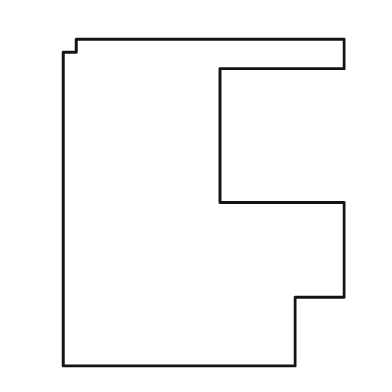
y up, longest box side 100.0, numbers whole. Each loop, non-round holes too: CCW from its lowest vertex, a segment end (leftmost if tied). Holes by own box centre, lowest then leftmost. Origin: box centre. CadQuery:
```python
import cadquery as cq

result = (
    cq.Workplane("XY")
    .moveTo(-43.0, -50.0)
    .lineTo(28.0, -50.0)
    .lineTo(28.0, -29.0)
    .lineTo(43.0, -29.0)
    .lineTo(43.0, 0.0)
    .lineTo(5.0, 0.0)
    .lineTo(5.0, 41.0)
    .lineTo(43.0, 41.0)
    .lineTo(43.0, 50.0)
    .lineTo(-39.0, 50.0)
    .lineTo(-39.0, 46.0)
    .lineTo(-43.0, 46.0)
    .close()
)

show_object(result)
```